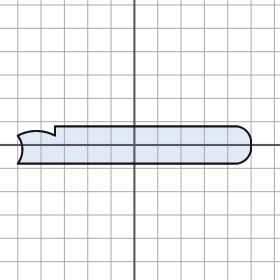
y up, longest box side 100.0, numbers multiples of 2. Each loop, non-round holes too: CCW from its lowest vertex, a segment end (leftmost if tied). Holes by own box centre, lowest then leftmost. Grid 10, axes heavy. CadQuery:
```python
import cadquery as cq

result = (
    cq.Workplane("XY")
    .moveTo(-50.0, -8.0)
    .lineTo(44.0, -8.0)
    .threePointArc((48.0, -6.0), (50.0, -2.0))
    .lineTo(50.0, 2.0)
    .threePointArc((48.0, 6.0), (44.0, 8.0))
    .lineTo(-34.0, 8.0)
    .lineTo(-34.0, 4.0)
    .threePointArc((-42.0, 6.0), (-50.0, 4.0))
    .threePointArc((-48.0, -2.0), (-50.0, -8.0))
    .close()
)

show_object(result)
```